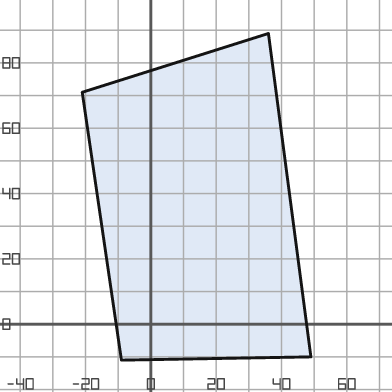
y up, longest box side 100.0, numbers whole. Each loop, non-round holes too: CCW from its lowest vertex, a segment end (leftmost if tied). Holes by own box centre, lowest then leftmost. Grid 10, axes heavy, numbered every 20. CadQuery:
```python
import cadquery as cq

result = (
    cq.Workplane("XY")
    .moveTo(-9.0, -11.0)
    .lineTo(49.0, -10.0)
    .lineTo(36.0, 89.0)
    .lineTo(-21.0, 71.0)
    .close()
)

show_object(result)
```